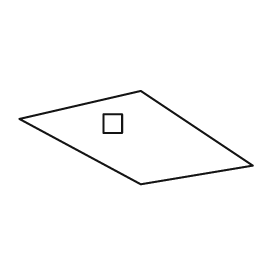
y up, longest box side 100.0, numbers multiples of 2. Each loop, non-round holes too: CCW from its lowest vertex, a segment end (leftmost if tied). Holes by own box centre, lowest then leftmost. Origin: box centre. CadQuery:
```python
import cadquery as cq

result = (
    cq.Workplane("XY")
    .moveTo(2.0, -20.0)
    .lineTo(50.0, -12.0)
    .lineTo(2.0, 20.0)
    .lineTo(-50.0, 8.0)
    .close()
    .moveTo(-14.0, 2.0)
    .lineTo(-6.0, 2.0)
    .lineTo(-6.0, 10.0)
    .lineTo(-14.0, 10.0)
    .close()
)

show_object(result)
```